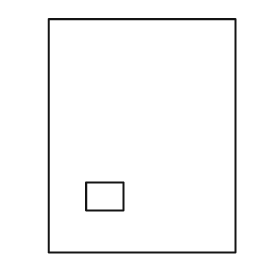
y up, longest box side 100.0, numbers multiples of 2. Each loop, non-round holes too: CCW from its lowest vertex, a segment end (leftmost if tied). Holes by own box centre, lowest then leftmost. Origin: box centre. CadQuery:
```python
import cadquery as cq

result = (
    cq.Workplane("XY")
    .moveTo(-40.0, -50.0)
    .lineTo(40.0, -50.0)
    .lineTo(40.0, 50.0)
    .lineTo(-40.0, 50.0)
    .close()
    .moveTo(-24.0, -32.0)
    .lineTo(-8.0, -32.0)
    .lineTo(-8.0, -20.0)
    .lineTo(-24.0, -20.0)
    .close()
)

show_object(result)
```